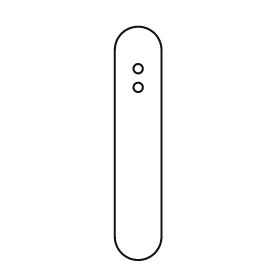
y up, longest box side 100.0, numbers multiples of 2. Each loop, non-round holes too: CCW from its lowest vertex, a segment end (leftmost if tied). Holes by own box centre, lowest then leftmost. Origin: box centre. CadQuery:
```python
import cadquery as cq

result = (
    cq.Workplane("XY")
    .moveTo(-10.0, -40.0)
    .threePointArc((0.0, -50.0), (10.0, -40.0))
    .lineTo(10.0, 40.0)
    .threePointArc((0.0, 50.0), (-10.0, 40.0))
    .close()
    .moveTo(0.0, 24.0)
    .circle(2.0)
    .moveTo(0.0, 32.0)
    .circle(2.0)
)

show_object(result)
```